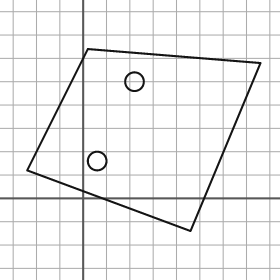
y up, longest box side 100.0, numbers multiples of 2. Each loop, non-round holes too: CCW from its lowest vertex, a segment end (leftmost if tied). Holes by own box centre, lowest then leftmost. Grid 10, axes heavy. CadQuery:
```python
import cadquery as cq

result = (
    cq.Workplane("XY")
    .moveTo(46.0, -14.0)
    .lineTo(76.0, 58.0)
    .lineTo(2.0, 64.0)
    .lineTo(-24.0, 12.0)
    .close()
    .moveTo(6.0, 16.0)
    .circle(4.0)
    .moveTo(22.0, 50.0)
    .circle(4.0)
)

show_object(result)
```